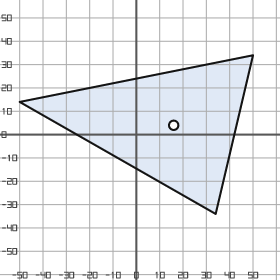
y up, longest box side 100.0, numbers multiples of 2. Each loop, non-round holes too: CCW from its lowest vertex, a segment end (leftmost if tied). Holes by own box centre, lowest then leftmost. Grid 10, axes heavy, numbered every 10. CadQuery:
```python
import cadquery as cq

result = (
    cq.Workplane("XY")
    .moveTo(34.0, -34.0)
    .lineTo(50.0, 34.0)
    .lineTo(-50.0, 14.0)
    .close()
    .moveTo(16.0, 4.0)
    .circle(2.0)
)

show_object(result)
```